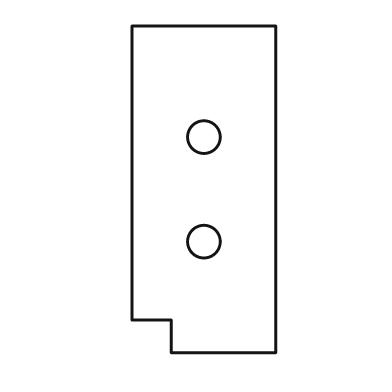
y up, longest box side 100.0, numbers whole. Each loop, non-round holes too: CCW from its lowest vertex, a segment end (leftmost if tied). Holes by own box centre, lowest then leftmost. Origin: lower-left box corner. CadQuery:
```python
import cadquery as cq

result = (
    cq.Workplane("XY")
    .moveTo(12.0, 0.0)
    .lineTo(44.0, 0.0)
    .lineTo(44.0, 100.0)
    .lineTo(0.0, 100.0)
    .lineTo(0.0, 10.0)
    .lineTo(12.0, 10.0)
    .close()
    .moveTo(22.0, 34.0)
    .circle(5.0)
    .moveTo(22.0, 66.0)
    .circle(5.0)
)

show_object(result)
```